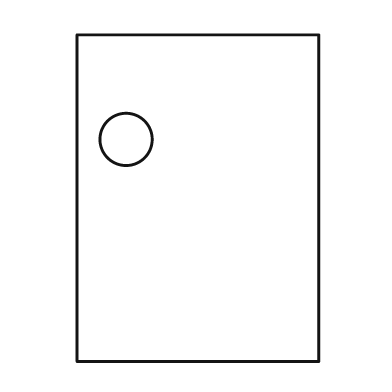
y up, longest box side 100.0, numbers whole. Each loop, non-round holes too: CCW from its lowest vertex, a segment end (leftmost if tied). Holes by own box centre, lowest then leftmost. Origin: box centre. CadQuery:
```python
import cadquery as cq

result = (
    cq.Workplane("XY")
    .moveTo(-37.0, -50.0)
    .lineTo(37.0, -50.0)
    .lineTo(37.0, 50.0)
    .lineTo(-37.0, 50.0)
    .close()
    .moveTo(-22.0, 18.0)
    .circle(8.0)
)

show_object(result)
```